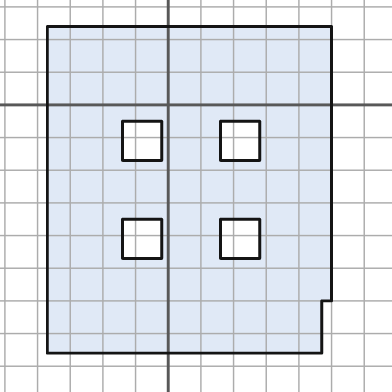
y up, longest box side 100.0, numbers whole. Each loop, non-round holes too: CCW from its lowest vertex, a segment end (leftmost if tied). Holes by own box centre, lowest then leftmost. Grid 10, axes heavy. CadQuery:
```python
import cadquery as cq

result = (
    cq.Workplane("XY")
    .moveTo(-37.0, -76.0)
    .lineTo(47.0, -76.0)
    .lineTo(47.0, -60.0)
    .lineTo(50.0, -60.0)
    .lineTo(50.0, 24.0)
    .lineTo(-37.0, 24.0)
    .close()
    .moveTo(-14.0, -47.0)
    .lineTo(-2.0, -47.0)
    .lineTo(-2.0, -35.0)
    .lineTo(-14.0, -35.0)
    .close()
    .moveTo(16.0, -47.0)
    .lineTo(28.0, -47.0)
    .lineTo(28.0, -35.0)
    .lineTo(16.0, -35.0)
    .close()
    .moveTo(-14.0, -17.0)
    .lineTo(-2.0, -17.0)
    .lineTo(-2.0, -5.0)
    .lineTo(-14.0, -5.0)
    .close()
    .moveTo(16.0, -17.0)
    .lineTo(28.0, -17.0)
    .lineTo(28.0, -5.0)
    .lineTo(16.0, -5.0)
    .close()
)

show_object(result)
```